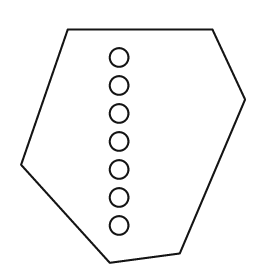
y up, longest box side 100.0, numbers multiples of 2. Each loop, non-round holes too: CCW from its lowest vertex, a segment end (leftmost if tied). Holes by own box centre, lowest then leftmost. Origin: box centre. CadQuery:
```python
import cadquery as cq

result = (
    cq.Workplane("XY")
    .moveTo(-10.0, -50.0)
    .lineTo(20.0, -46.0)
    .lineTo(48.0, 20.0)
    .lineTo(34.0, 50.0)
    .lineTo(-28.0, 50.0)
    .lineTo(-48.0, -8.0)
    .close()
    .moveTo(-6.0, -34.0)
    .circle(4.0)
    .moveTo(-6.0, -22.0)
    .circle(4.0)
    .moveTo(-6.0, -10.0)
    .circle(4.0)
    .moveTo(-6.0, 2.0)
    .circle(4.0)
    .moveTo(-6.0, 14.0)
    .circle(4.0)
    .moveTo(-6.0, 26.0)
    .circle(4.0)
    .moveTo(-6.0, 38.0)
    .circle(4.0)
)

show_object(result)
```